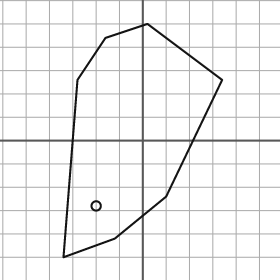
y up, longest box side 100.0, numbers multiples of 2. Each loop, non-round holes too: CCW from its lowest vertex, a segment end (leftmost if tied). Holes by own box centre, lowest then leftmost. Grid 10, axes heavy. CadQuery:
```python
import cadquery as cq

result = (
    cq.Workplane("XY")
    .moveTo(-34.0, -50.0)
    .lineTo(-12.0, -42.0)
    .lineTo(10.0, -24.0)
    .lineTo(34.0, 26.0)
    .lineTo(2.0, 50.0)
    .lineTo(-16.0, 44.0)
    .lineTo(-28.0, 26.0)
    .close()
    .moveTo(-20.0, -28.0)
    .circle(2.0)
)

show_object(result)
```